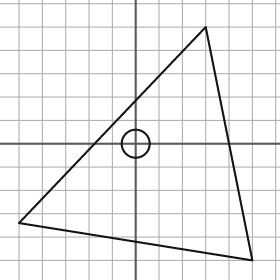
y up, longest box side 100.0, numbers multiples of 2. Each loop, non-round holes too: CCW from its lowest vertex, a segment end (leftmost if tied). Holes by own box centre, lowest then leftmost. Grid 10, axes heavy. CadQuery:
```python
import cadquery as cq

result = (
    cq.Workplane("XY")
    .moveTo(50.0, -50.0)
    .lineTo(30.0, 50.0)
    .lineTo(-50.0, -34.0)
    .close()
    .moveTo(0.0, 0.0)
    .circle(6.0)
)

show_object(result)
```